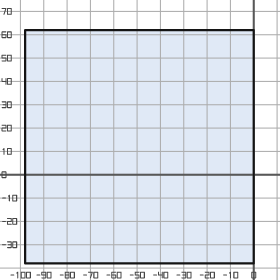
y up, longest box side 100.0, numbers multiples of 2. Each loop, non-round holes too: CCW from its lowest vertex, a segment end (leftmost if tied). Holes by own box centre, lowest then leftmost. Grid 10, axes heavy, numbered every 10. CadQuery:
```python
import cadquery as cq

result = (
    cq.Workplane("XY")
    .moveTo(-98.0, -38.0)
    .lineTo(0.0, -38.0)
    .lineTo(0.0, 62.0)
    .lineTo(-98.0, 62.0)
    .close()
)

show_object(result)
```